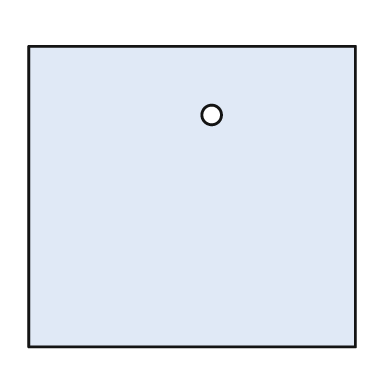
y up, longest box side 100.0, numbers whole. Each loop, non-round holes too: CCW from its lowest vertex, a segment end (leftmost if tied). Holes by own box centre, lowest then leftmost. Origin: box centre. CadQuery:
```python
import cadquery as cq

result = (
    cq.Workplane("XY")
    .moveTo(-50.0, -46.0)
    .lineTo(50.0, -46.0)
    .lineTo(50.0, 46.0)
    .lineTo(-50.0, 46.0)
    .close()
    .moveTo(6.0, 25.0)
    .circle(3.0)
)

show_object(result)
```